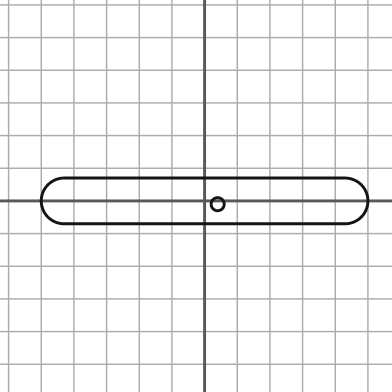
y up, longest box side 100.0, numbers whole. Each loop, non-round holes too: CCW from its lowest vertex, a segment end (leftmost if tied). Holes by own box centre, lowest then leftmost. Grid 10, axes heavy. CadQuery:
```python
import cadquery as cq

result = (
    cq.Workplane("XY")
    .moveTo(-43.0, -7.0)
    .lineTo(43.0, -7.0)
    .threePointArc((50.0, 0.0), (43.0, 7.0))
    .lineTo(-43.0, 7.0)
    .threePointArc((-50.0, 0.0), (-43.0, -7.0))
    .close()
    .moveTo(4.0, -1.0)
    .circle(2.0)
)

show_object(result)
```